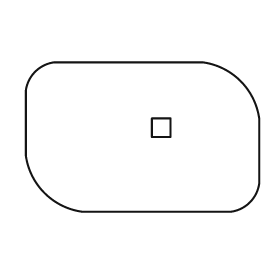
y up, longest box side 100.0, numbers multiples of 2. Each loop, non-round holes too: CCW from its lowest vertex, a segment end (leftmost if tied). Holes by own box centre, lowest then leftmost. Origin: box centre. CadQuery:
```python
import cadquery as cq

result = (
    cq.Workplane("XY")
    .moveTo(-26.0, -32.0)
    .lineTo(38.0, -32.0)
    .threePointArc((46.0, -28.0), (50.0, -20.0))
    .lineTo(50.0, 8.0)
    .threePointArc((42.0, 24.0), (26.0, 32.0))
    .lineTo(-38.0, 32.0)
    .threePointArc((-46.0, 28.0), (-50.0, 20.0))
    .lineTo(-50.0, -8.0)
    .threePointArc((-42.0, -24.0), (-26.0, -32.0))
    .close()
    .moveTo(4.0, 0.0)
    .lineTo(12.0, 0.0)
    .lineTo(12.0, 8.0)
    .lineTo(4.0, 8.0)
    .close()
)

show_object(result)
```